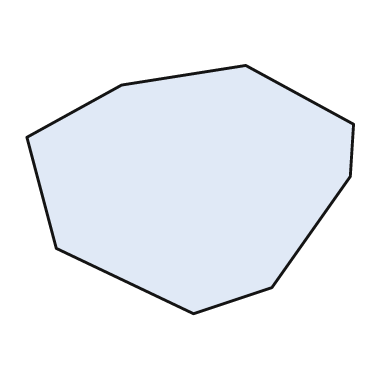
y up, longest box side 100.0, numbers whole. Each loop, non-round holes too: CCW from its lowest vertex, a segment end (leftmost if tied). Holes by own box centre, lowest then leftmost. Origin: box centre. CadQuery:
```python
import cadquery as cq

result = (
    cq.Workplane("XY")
    .moveTo(1.0, -38.0)
    .lineTo(25.0, -30.0)
    .lineTo(49.0, 4.0)
    .lineTo(50.0, 20.0)
    .lineTo(17.0, 38.0)
    .lineTo(-21.0, 32.0)
    .lineTo(-50.0, 16.0)
    .lineTo(-41.0, -18.0)
    .close()
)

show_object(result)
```